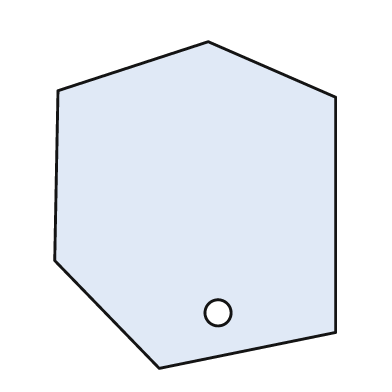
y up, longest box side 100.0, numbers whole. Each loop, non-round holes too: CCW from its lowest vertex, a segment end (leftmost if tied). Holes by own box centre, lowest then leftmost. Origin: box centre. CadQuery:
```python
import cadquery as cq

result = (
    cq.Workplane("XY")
    .moveTo(-11.0, -50.0)
    .lineTo(43.0, -39.0)
    .lineTo(43.0, 33.0)
    .lineTo(4.0, 50.0)
    .lineTo(-42.0, 35.0)
    .lineTo(-43.0, -17.0)
    .close()
    .moveTo(7.0, -33.0)
    .circle(4.0)
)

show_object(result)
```